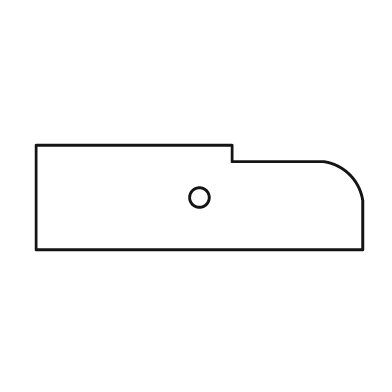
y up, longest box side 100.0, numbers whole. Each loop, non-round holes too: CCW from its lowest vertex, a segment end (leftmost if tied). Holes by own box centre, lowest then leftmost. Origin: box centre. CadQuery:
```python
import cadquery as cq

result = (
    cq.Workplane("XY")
    .moveTo(-50.0, -16.0)
    .lineTo(50.0, -16.0)
    .lineTo(50.0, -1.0)
    .threePointArc((46.0, 7.0), (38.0, 11.0))
    .lineTo(10.0, 11.0)
    .lineTo(10.0, 16.0)
    .lineTo(-50.0, 16.0)
    .close()
    .moveTo(0.0, 0.0)
    .circle(3.0)
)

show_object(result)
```